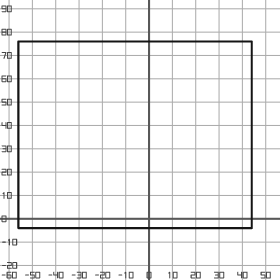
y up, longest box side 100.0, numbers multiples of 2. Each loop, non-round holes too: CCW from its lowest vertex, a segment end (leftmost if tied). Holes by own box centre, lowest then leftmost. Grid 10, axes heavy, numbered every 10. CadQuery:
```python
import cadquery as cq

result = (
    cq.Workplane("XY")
    .moveTo(-56.0, -4.0)
    .lineTo(44.0, -4.0)
    .lineTo(44.0, 76.0)
    .lineTo(-56.0, 76.0)
    .close()
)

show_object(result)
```